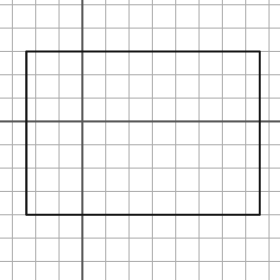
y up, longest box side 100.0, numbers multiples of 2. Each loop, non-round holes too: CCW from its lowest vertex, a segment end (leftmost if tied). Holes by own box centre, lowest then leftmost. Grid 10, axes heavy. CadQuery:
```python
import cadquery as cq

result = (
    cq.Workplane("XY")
    .moveTo(-24.0, -40.0)
    .lineTo(76.0, -40.0)
    .lineTo(76.0, 30.0)
    .lineTo(-24.0, 30.0)
    .close()
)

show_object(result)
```